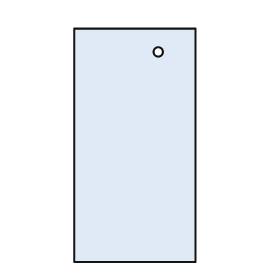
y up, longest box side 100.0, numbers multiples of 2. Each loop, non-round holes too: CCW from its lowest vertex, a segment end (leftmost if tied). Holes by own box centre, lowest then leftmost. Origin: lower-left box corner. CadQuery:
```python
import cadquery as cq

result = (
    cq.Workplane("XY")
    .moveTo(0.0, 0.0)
    .lineTo(52.0, 0.0)
    .lineTo(52.0, 100.0)
    .lineTo(0.0, 100.0)
    .close()
    .moveTo(36.0, 90.0)
    .circle(2.0)
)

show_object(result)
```